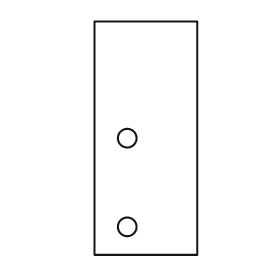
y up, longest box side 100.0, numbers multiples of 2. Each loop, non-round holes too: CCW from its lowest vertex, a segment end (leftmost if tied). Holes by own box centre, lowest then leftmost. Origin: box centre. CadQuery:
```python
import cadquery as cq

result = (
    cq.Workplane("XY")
    .moveTo(-22.0, -50.0)
    .lineTo(22.0, -50.0)
    .lineTo(22.0, 50.0)
    .lineTo(-22.0, 50.0)
    .close()
    .moveTo(-8.0, -38.0)
    .circle(4.0)
    .moveTo(-8.0, 0.0)
    .circle(4.0)
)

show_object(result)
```